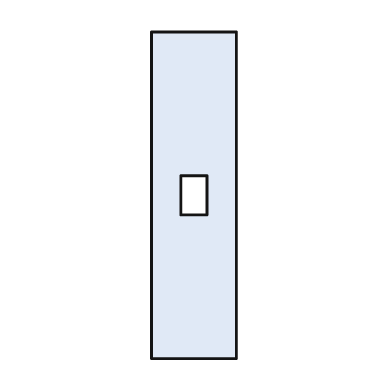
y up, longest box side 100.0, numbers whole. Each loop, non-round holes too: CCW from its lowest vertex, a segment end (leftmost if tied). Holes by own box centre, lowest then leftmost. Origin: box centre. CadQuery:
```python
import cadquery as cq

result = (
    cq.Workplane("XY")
    .moveTo(-13.0, -50.0)
    .lineTo(13.0, -50.0)
    .lineTo(13.0, 50.0)
    .lineTo(-13.0, 50.0)
    .close()
    .moveTo(-4.0, -6.0)
    .lineTo(4.0, -6.0)
    .lineTo(4.0, 6.0)
    .lineTo(-4.0, 6.0)
    .close()
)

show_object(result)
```